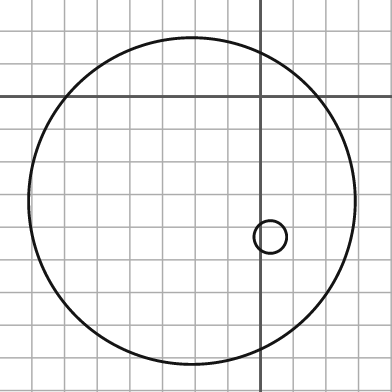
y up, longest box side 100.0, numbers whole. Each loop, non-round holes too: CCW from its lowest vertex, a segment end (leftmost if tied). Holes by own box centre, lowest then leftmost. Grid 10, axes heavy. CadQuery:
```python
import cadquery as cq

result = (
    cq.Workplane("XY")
    .moveTo(-21.0, -32.0)
    .circle(50.0)
    .moveTo(3.0, -43.0)
    .circle(5.0)
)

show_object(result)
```